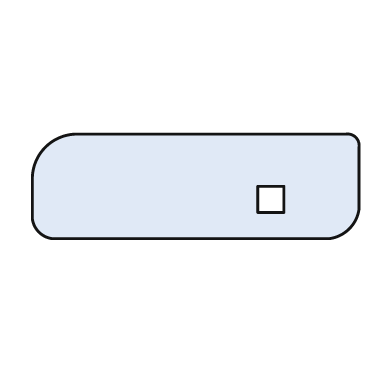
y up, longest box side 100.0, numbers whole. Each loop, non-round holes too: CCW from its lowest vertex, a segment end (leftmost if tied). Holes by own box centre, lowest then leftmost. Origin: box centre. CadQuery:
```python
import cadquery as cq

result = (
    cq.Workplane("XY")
    .moveTo(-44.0, -16.0)
    .lineTo(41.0, -16.0)
    .threePointArc((47.0, -13.0), (50.0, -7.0))
    .lineTo(50.0, 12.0)
    .threePointArc((49.0, 15.0), (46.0, 16.0))
    .lineTo(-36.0, 16.0)
    .threePointArc((-46.0, 12.0), (-50.0, 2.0))
    .lineTo(-50.0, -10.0)
    .threePointArc((-48.0, -14.0), (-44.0, -16.0))
    .close()
    .moveTo(19.0, -8.0)
    .lineTo(27.0, -8.0)
    .lineTo(27.0, 0.0)
    .lineTo(19.0, 0.0)
    .close()
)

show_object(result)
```